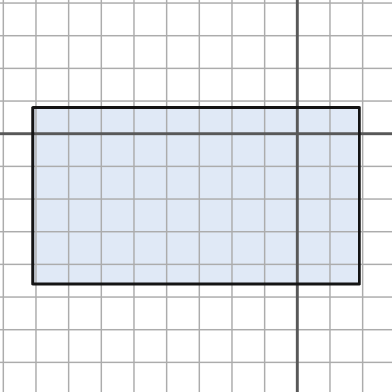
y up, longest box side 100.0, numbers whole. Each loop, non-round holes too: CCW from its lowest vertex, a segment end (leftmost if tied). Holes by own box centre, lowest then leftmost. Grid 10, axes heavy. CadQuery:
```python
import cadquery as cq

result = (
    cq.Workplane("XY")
    .moveTo(-81.0, -46.0)
    .lineTo(19.0, -46.0)
    .lineTo(19.0, 8.0)
    .lineTo(-81.0, 8.0)
    .close()
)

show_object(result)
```